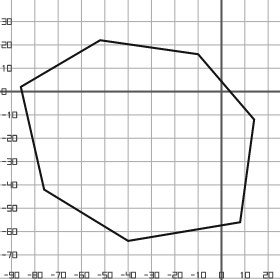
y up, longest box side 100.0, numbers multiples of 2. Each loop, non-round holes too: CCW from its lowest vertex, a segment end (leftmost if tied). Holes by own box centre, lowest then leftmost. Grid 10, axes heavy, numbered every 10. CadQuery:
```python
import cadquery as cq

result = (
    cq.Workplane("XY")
    .moveTo(-40.0, -64.0)
    .lineTo(8.0, -56.0)
    .lineTo(14.0, -12.0)
    .lineTo(-10.0, 16.0)
    .lineTo(-52.0, 22.0)
    .lineTo(-86.0, 2.0)
    .lineTo(-76.0, -42.0)
    .close()
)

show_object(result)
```